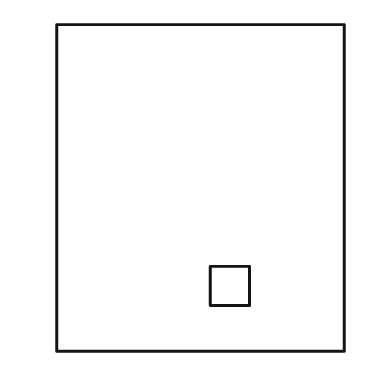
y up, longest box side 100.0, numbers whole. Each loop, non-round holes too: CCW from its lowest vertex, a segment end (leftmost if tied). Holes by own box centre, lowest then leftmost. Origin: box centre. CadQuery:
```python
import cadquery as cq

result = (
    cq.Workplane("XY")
    .moveTo(-44.0, -50.0)
    .lineTo(44.0, -50.0)
    .lineTo(44.0, 50.0)
    .lineTo(-44.0, 50.0)
    .close()
    .moveTo(3.0, -36.0)
    .lineTo(15.0, -36.0)
    .lineTo(15.0, -24.0)
    .lineTo(3.0, -24.0)
    .close()
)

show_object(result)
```